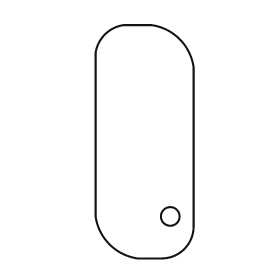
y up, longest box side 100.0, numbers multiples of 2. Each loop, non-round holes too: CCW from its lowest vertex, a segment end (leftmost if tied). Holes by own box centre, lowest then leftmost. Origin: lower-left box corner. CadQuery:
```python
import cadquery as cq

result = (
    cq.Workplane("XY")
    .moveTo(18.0, 0.0)
    .lineTo(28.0, 0.0)
    .threePointArc((38.0, 4.0), (42.0, 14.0))
    .lineTo(42.0, 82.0)
    .threePointArc((36.0, 94.0), (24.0, 100.0))
    .lineTo(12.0, 100.0)
    .threePointArc((4.0, 96.0), (0.0, 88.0))
    .lineTo(0.0, 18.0)
    .threePointArc((6.0, 6.0), (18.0, 0.0))
    .close()
    .moveTo(32.0, 18.0)
    .circle(4.0)
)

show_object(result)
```